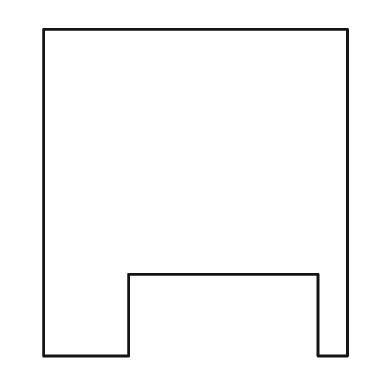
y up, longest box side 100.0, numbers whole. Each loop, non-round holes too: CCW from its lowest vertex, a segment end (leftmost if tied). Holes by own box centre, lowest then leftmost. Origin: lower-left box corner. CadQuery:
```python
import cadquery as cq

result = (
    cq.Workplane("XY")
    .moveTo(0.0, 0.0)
    .lineTo(26.0, 0.0)
    .lineTo(26.0, 25.0)
    .lineTo(84.0, 25.0)
    .lineTo(84.0, 0.0)
    .lineTo(93.0, 0.0)
    .lineTo(93.0, 100.0)
    .lineTo(0.0, 100.0)
    .close()
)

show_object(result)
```